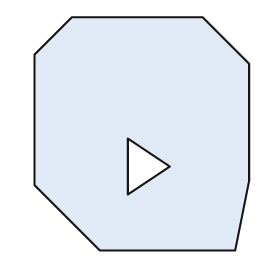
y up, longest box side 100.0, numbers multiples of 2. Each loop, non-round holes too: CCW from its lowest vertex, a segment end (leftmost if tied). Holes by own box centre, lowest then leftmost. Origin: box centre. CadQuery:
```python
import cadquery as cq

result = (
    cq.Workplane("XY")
    .moveTo(-18.0, -50.0)
    .lineTo(40.0, -50.0)
    .lineTo(46.0, -20.0)
    .lineTo(46.0, 30.0)
    .lineTo(26.0, 50.0)
    .lineTo(-30.0, 50.0)
    .lineTo(-46.0, 34.0)
    .lineTo(-46.0, -22.0)
    .close()
    .moveTo(-6.0, -26.0)
    .lineTo(12.0, -14.0)
    .lineTo(-6.0, -2.0)
    .close()
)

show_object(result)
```